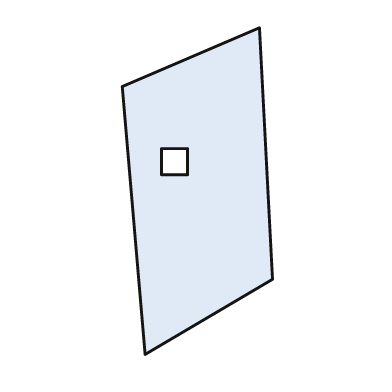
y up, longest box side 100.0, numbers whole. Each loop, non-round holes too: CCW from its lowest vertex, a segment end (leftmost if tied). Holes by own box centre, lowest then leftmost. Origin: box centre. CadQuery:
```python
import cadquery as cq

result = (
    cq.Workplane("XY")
    .moveTo(-16.0, -50.0)
    .lineTo(23.0, -27.0)
    .lineTo(19.0, 50.0)
    .lineTo(-23.0, 32.0)
    .close()
    .moveTo(-11.0, 5.0)
    .lineTo(-3.0, 5.0)
    .lineTo(-3.0, 13.0)
    .lineTo(-11.0, 13.0)
    .close()
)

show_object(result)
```